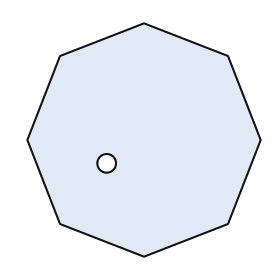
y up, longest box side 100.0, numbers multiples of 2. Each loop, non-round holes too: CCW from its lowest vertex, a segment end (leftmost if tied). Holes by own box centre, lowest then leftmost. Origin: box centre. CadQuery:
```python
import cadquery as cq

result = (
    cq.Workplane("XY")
    .moveTo(0.0, -50.0)
    .lineTo(36.0, -36.0)
    .lineTo(50.0, 0.0)
    .lineTo(36.0, 36.0)
    .lineTo(0.0, 50.0)
    .lineTo(-36.0, 36.0)
    .lineTo(-50.0, 0.0)
    .lineTo(-36.0, -36.0)
    .close()
    .moveTo(-16.0, -10.0)
    .circle(4.0)
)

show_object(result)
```